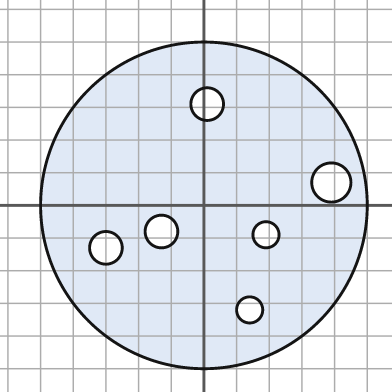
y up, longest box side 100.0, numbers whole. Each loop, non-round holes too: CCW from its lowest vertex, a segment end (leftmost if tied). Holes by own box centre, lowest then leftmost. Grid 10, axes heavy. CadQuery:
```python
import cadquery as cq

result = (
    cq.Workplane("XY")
    .moveTo(0.0, 0.0)
    .circle(50.0)
    .moveTo(14.0, -32.0)
    .circle(4.0)
    .moveTo(-30.0, -13.0)
    .circle(5.0)
    .moveTo(19.0, -9.0)
    .circle(4.0)
    .moveTo(-13.0, -8.0)
    .circle(5.0)
    .moveTo(39.0, 7.0)
    .circle(6.0)
    .moveTo(1.0, 31.0)
    .circle(5.0)
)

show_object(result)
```